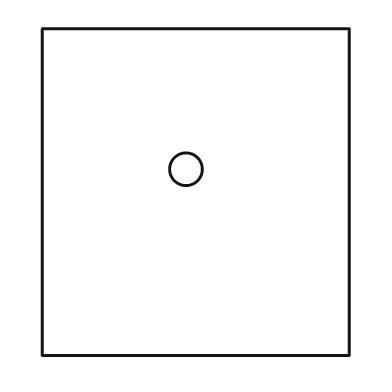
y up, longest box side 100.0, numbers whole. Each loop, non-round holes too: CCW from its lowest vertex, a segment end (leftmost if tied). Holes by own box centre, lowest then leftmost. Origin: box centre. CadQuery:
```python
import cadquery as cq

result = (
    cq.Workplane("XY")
    .moveTo(-47.0, -50.0)
    .lineTo(47.0, -50.0)
    .lineTo(47.0, 50.0)
    .lineTo(-47.0, 50.0)
    .close()
    .moveTo(-3.0, 7.0)
    .circle(5.0)
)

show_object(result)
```